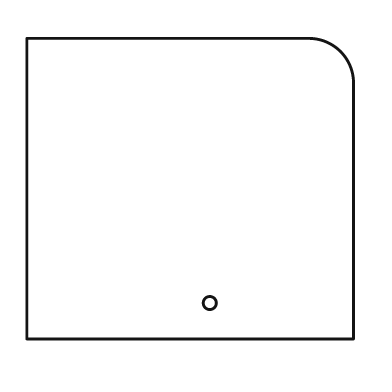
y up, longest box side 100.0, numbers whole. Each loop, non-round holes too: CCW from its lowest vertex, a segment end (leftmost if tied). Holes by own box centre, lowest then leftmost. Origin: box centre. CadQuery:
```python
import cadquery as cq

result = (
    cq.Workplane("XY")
    .moveTo(-50.0, -46.0)
    .lineTo(50.0, -46.0)
    .lineTo(50.0, 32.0)
    .threePointArc((46.0, 42.0), (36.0, 46.0))
    .lineTo(-50.0, 46.0)
    .close()
    .moveTo(6.0, -35.0)
    .circle(2.0)
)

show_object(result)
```